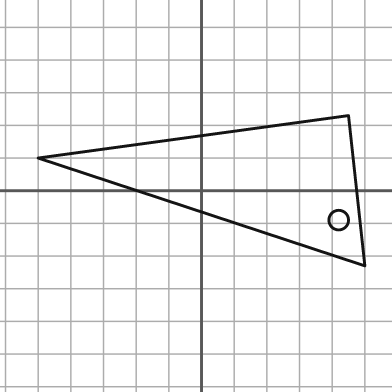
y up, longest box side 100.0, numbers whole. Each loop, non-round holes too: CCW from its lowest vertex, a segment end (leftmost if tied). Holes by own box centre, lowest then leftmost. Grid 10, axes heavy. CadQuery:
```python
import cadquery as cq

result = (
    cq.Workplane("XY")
    .moveTo(50.0, -23.0)
    .lineTo(45.0, 23.0)
    .lineTo(-50.0, 10.0)
    .close()
    .moveTo(42.0, -9.0)
    .circle(3.0)
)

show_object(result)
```